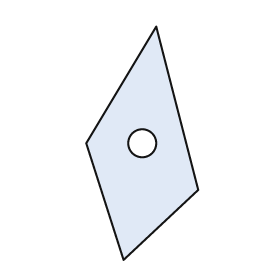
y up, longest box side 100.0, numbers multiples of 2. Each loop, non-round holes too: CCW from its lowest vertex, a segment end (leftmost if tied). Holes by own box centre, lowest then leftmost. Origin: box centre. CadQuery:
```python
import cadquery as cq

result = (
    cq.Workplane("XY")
    .moveTo(-8.0, -50.0)
    .lineTo(24.0, -20.0)
    .lineTo(6.0, 50.0)
    .lineTo(-24.0, 0.0)
    .close()
    .moveTo(0.0, 0.0)
    .circle(6.0)
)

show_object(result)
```